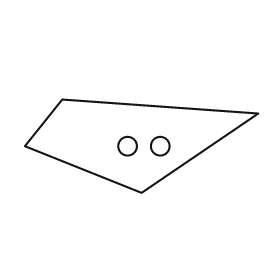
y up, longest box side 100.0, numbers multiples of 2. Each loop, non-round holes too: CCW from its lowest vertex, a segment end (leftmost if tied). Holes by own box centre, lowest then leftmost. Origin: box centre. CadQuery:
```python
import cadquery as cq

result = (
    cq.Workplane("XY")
    .moveTo(0.0, -20.0)
    .lineTo(50.0, 14.0)
    .lineTo(-34.0, 20.0)
    .lineTo(-50.0, 0.0)
    .close()
    .moveTo(-6.0, 0.0)
    .circle(4.0)
    .moveTo(8.0, 0.0)
    .circle(4.0)
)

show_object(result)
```